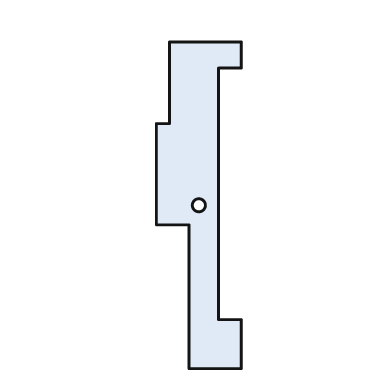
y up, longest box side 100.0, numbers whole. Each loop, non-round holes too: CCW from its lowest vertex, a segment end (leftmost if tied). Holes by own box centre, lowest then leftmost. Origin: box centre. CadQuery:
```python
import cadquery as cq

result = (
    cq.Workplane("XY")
    .moveTo(-3.0, -50.0)
    .lineTo(13.0, -50.0)
    .lineTo(13.0, -35.0)
    .lineTo(6.0, -35.0)
    .lineTo(6.0, 42.0)
    .lineTo(13.0, 42.0)
    .lineTo(13.0, 50.0)
    .lineTo(-9.0, 50.0)
    .lineTo(-9.0, 25.0)
    .lineTo(-13.0, 25.0)
    .lineTo(-13.0, -6.0)
    .lineTo(-3.0, -6.0)
    .close()
    .moveTo(0.0, 0.0)
    .circle(2.0)
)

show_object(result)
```